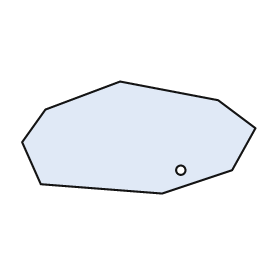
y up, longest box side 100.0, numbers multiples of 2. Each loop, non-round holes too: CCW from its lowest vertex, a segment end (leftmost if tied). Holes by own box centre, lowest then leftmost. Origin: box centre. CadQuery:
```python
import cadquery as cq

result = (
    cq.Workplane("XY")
    .moveTo(10.0, -24.0)
    .lineTo(40.0, -14.0)
    .lineTo(50.0, 4.0)
    .lineTo(34.0, 16.0)
    .lineTo(-8.0, 24.0)
    .lineTo(-40.0, 12.0)
    .lineTo(-50.0, -2.0)
    .lineTo(-42.0, -20.0)
    .close()
    .moveTo(18.0, -14.0)
    .circle(2.0)
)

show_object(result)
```